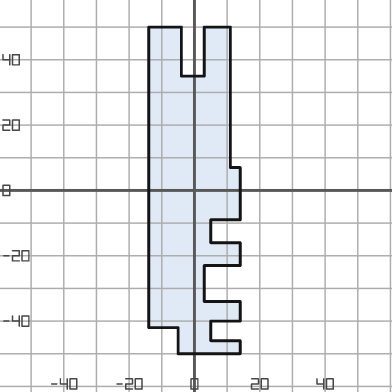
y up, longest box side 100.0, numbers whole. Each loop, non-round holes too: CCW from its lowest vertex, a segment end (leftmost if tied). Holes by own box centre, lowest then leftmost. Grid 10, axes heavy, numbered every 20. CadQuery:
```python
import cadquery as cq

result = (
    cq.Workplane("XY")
    .moveTo(-5.0, -50.0)
    .lineTo(14.0, -50.0)
    .lineTo(14.0, -46.0)
    .lineTo(5.0, -46.0)
    .lineTo(5.0, -40.0)
    .lineTo(14.0, -40.0)
    .lineTo(14.0, -34.0)
    .lineTo(3.0, -34.0)
    .lineTo(3.0, -23.0)
    .lineTo(14.0, -23.0)
    .lineTo(14.0, -16.0)
    .lineTo(5.0, -16.0)
    .lineTo(5.0, -9.0)
    .lineTo(14.0, -9.0)
    .lineTo(14.0, 7.0)
    .lineTo(11.0, 7.0)
    .lineTo(11.0, 50.0)
    .lineTo(3.0, 50.0)
    .lineTo(3.0, 35.0)
    .lineTo(-4.0, 35.0)
    .lineTo(-4.0, 50.0)
    .lineTo(-14.0, 50.0)
    .lineTo(-14.0, -42.0)
    .lineTo(-5.0, -42.0)
    .close()
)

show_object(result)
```